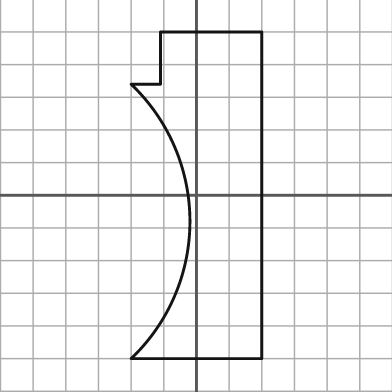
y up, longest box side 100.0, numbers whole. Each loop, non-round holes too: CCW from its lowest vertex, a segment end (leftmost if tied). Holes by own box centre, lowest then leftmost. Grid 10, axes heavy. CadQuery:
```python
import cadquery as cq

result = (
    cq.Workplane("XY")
    .moveTo(-20.0, -50.0)
    .lineTo(20.0, -50.0)
    .lineTo(20.0, 50.0)
    .lineTo(-11.0, 50.0)
    .lineTo(-11.0, 34.0)
    .lineTo(-20.0, 34.0)
    .threePointArc((-2.0, -8.0), (-20.0, -50.0))
    .close()
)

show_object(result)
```